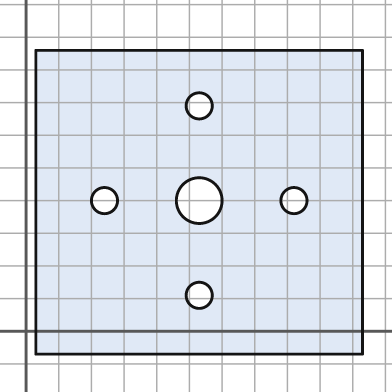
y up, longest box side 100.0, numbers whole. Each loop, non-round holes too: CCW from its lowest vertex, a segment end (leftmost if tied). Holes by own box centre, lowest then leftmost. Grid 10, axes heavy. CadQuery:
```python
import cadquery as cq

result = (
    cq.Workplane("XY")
    .moveTo(3.0, -7.0)
    .lineTo(103.0, -7.0)
    .lineTo(103.0, 86.0)
    .lineTo(3.0, 86.0)
    .close()
    .moveTo(53.0, 11.0)
    .circle(4.0)
    .moveTo(24.0, 40.0)
    .circle(4.0)
    .moveTo(53.0, 40.0)
    .circle(7.0)
    .moveTo(82.0, 40.0)
    .circle(4.0)
    .moveTo(53.0, 69.0)
    .circle(4.0)
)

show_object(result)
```